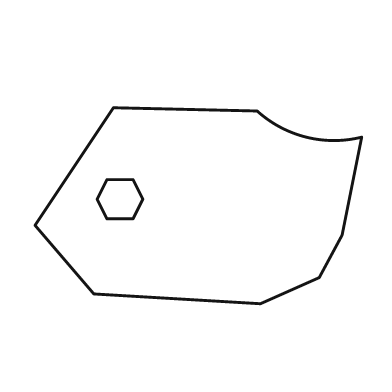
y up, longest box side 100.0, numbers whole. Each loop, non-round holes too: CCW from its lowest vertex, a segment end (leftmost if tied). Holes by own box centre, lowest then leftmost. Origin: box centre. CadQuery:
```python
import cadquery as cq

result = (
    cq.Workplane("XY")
    .moveTo(19.0, -30.0)
    .lineTo(37.0, -22.0)
    .lineTo(44.0, -9.0)
    .lineTo(50.0, 21.0)
    .threePointArc((33.0, 21.0), (18.0, 29.0))
    .lineTo(-26.0, 30.0)
    .lineTo(-50.0, -6.0)
    .lineTo(-32.0, -27.0)
    .close()
    .moveTo(-28.0, -4.0)
    .lineTo(-20.0, -4.0)
    .lineTo(-17.0, 2.0)
    .lineTo(-20.0, 8.0)
    .lineTo(-28.0, 8.0)
    .lineTo(-31.0, 2.0)
    .close()
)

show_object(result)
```